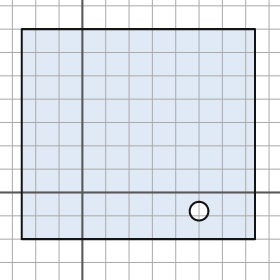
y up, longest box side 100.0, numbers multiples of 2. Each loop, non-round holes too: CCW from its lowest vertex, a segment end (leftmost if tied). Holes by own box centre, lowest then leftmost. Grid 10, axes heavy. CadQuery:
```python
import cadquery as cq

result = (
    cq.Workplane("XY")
    .moveTo(-26.0, -20.0)
    .lineTo(74.0, -20.0)
    .lineTo(74.0, 70.0)
    .lineTo(-26.0, 70.0)
    .close()
    .moveTo(50.0, -8.0)
    .circle(4.0)
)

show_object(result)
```